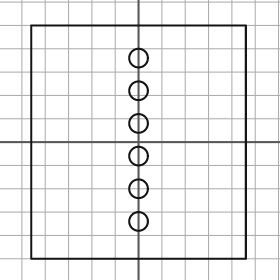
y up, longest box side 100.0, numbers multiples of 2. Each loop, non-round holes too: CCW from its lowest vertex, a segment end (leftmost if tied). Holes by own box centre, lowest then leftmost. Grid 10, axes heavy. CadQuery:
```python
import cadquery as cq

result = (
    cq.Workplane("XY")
    .moveTo(-46.0, -50.0)
    .lineTo(46.0, -50.0)
    .lineTo(46.0, 50.0)
    .lineTo(-46.0, 50.0)
    .close()
    .moveTo(0.0, -34.0)
    .circle(4.0)
    .moveTo(0.0, -20.0)
    .circle(4.0)
    .moveTo(0.0, -6.0)
    .circle(4.0)
    .moveTo(0.0, 8.0)
    .circle(4.0)
    .moveTo(0.0, 22.0)
    .circle(4.0)
    .moveTo(0.0, 36.0)
    .circle(4.0)
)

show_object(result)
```